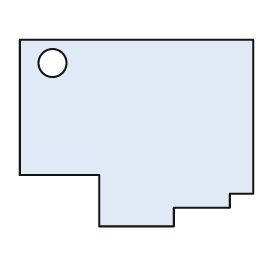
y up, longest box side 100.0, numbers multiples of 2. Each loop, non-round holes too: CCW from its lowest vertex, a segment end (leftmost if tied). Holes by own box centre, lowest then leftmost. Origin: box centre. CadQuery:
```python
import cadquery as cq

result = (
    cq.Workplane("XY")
    .moveTo(-16.0, -40.0)
    .lineTo(16.0, -40.0)
    .lineTo(16.0, -32.0)
    .lineTo(40.0, -32.0)
    .lineTo(40.0, -26.0)
    .lineTo(50.0, -26.0)
    .lineTo(50.0, 40.0)
    .lineTo(-50.0, 40.0)
    .lineTo(-50.0, -18.0)
    .lineTo(-16.0, -18.0)
    .close()
    .moveTo(-36.0, 30.0)
    .circle(6.0)
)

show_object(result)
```